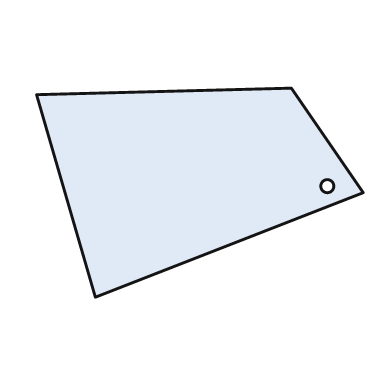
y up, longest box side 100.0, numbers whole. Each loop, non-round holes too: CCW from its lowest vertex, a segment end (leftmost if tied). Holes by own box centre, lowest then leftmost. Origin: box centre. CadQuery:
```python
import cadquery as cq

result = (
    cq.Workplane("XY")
    .moveTo(-32.0, -32.0)
    .lineTo(50.0, 0.0)
    .lineTo(28.0, 32.0)
    .lineTo(-50.0, 30.0)
    .close()
    .moveTo(39.0, 2.0)
    .circle(2.0)
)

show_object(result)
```